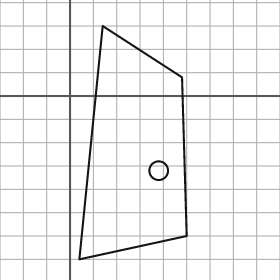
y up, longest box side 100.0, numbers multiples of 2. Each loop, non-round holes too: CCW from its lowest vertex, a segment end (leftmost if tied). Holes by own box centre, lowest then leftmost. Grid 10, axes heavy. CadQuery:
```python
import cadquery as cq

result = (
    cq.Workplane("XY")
    .moveTo(4.0, -70.0)
    .lineTo(50.0, -60.0)
    .lineTo(48.0, 8.0)
    .lineTo(14.0, 30.0)
    .close()
    .moveTo(38.0, -32.0)
    .circle(4.0)
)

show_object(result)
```